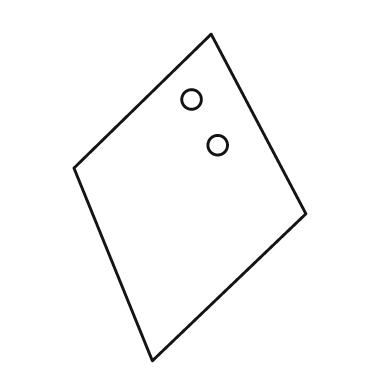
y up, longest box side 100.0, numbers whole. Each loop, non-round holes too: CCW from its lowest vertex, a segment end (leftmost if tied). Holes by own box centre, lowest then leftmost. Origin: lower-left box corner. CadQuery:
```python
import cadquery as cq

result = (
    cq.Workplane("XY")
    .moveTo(24.0, 0.0)
    .lineTo(71.0, 45.0)
    .lineTo(42.0, 100.0)
    .lineTo(0.0, 59.0)
    .close()
    .moveTo(44.0, 66.0)
    .circle(3.0)
    .moveTo(36.0, 80.0)
    .circle(3.0)
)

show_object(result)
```